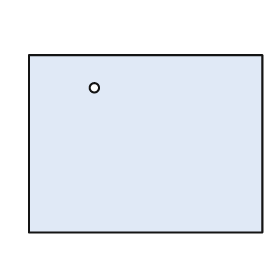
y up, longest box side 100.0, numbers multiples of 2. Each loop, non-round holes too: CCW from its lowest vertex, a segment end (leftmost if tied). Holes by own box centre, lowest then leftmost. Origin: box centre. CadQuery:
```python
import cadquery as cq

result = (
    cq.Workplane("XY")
    .moveTo(-50.0, -38.0)
    .lineTo(50.0, -38.0)
    .lineTo(50.0, 38.0)
    .lineTo(-50.0, 38.0)
    .close()
    .moveTo(-22.0, 24.0)
    .circle(2.0)
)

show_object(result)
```